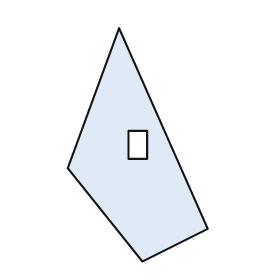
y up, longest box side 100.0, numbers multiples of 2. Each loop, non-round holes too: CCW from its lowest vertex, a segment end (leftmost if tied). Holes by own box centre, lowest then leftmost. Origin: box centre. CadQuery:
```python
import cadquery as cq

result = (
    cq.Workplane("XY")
    .moveTo(2.0, -50.0)
    .lineTo(30.0, -36.0)
    .lineTo(-8.0, 50.0)
    .lineTo(-30.0, -10.0)
    .close()
    .moveTo(-4.0, -6.0)
    .lineTo(4.0, -6.0)
    .lineTo(4.0, 6.0)
    .lineTo(-4.0, 6.0)
    .close()
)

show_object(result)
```